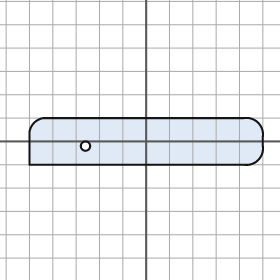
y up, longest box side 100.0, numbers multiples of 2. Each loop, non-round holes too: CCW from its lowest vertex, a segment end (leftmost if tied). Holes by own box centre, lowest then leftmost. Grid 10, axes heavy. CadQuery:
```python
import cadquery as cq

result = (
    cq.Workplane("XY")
    .moveTo(-50.0, -10.0)
    .lineTo(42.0, -10.0)
    .threePointArc((48.0, -8.0), (50.0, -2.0))
    .lineTo(50.0, 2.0)
    .threePointArc((48.0, 8.0), (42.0, 10.0))
    .lineTo(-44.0, 10.0)
    .threePointArc((-48.0, 8.0), (-50.0, 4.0))
    .close()
    .moveTo(-26.0, -2.0)
    .circle(2.0)
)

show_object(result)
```